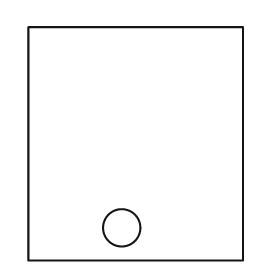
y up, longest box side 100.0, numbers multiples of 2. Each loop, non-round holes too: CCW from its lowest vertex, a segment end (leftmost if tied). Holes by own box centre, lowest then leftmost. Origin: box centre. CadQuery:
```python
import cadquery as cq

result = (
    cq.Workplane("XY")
    .moveTo(-46.0, -50.0)
    .lineTo(46.0, -50.0)
    .lineTo(46.0, 50.0)
    .lineTo(-46.0, 50.0)
    .close()
    .moveTo(-6.0, -36.0)
    .circle(8.0)
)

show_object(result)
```